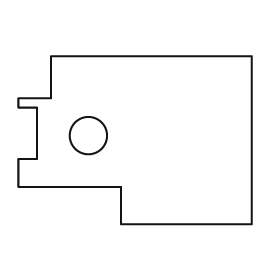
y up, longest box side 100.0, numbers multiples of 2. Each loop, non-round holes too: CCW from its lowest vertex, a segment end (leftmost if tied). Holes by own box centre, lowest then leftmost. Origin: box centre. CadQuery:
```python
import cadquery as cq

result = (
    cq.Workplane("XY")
    .moveTo(-6.0, -36.0)
    .lineTo(50.0, -36.0)
    .lineTo(50.0, 36.0)
    .lineTo(-36.0, 36.0)
    .lineTo(-36.0, 18.0)
    .lineTo(-50.0, 18.0)
    .lineTo(-50.0, 14.0)
    .lineTo(-42.0, 14.0)
    .lineTo(-42.0, -8.0)
    .lineTo(-50.0, -8.0)
    .lineTo(-50.0, -20.0)
    .lineTo(-6.0, -20.0)
    .close()
    .moveTo(-20.0, 2.0)
    .circle(8.0)
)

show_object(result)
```